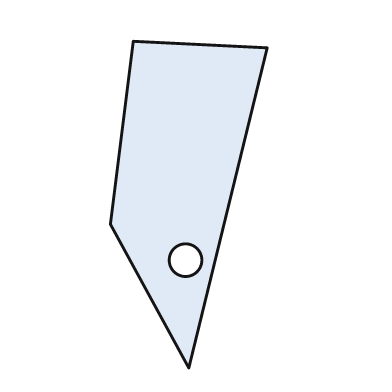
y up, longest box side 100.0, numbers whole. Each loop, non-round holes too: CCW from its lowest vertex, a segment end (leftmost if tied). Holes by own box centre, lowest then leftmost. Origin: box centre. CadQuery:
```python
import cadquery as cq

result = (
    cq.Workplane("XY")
    .moveTo(0.0, -50.0)
    .lineTo(24.0, 48.0)
    .lineTo(-17.0, 50.0)
    .lineTo(-24.0, -6.0)
    .close()
    .moveTo(-1.0, -17.0)
    .circle(5.0)
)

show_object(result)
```